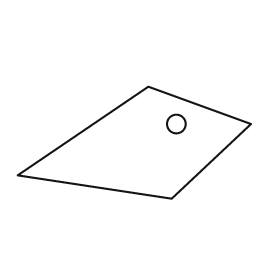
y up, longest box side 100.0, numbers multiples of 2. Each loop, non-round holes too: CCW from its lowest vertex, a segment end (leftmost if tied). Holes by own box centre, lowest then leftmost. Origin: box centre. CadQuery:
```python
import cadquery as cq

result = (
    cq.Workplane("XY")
    .moveTo(16.0, -24.0)
    .lineTo(50.0, 8.0)
    .lineTo(6.0, 24.0)
    .lineTo(-50.0, -14.0)
    .close()
    .moveTo(18.0, 8.0)
    .circle(4.0)
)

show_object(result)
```